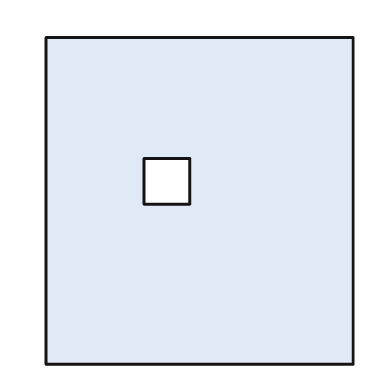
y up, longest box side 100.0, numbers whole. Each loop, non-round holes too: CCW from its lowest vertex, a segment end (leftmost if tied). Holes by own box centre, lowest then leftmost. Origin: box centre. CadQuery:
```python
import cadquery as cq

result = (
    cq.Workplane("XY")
    .moveTo(-47.0, -50.0)
    .lineTo(47.0, -50.0)
    .lineTo(47.0, 50.0)
    .lineTo(-47.0, 50.0)
    .close()
    .moveTo(-17.0, -1.0)
    .lineTo(-3.0, -1.0)
    .lineTo(-3.0, 13.0)
    .lineTo(-17.0, 13.0)
    .close()
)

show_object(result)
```